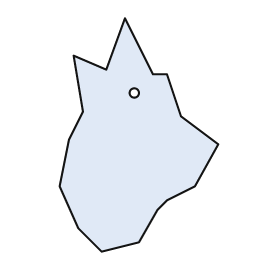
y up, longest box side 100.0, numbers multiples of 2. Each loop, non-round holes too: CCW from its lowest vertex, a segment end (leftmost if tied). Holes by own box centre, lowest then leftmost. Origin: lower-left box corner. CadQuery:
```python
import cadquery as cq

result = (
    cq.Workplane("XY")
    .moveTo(18.0, 0.0)
    .lineTo(34.0, 4.0)
    .lineTo(42.0, 18.0)
    .lineTo(46.0, 22.0)
    .lineTo(58.0, 28.0)
    .lineTo(68.0, 46.0)
    .lineTo(52.0, 58.0)
    .lineTo(46.0, 76.0)
    .lineTo(40.0, 76.0)
    .lineTo(28.0, 100.0)
    .lineTo(20.0, 78.0)
    .lineTo(6.0, 84.0)
    .lineTo(10.0, 60.0)
    .lineTo(4.0, 48.0)
    .lineTo(0.0, 28.0)
    .lineTo(8.0, 10.0)
    .close()
    .moveTo(32.0, 68.0)
    .circle(2.0)
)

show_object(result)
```